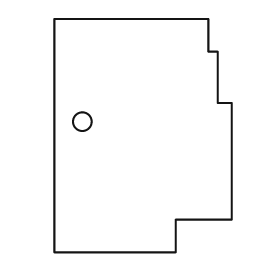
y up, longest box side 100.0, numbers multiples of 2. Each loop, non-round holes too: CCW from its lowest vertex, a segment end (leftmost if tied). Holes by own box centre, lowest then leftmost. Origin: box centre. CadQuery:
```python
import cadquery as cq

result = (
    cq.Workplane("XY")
    .moveTo(-38.0, -50.0)
    .lineTo(14.0, -50.0)
    .lineTo(14.0, -36.0)
    .lineTo(38.0, -36.0)
    .lineTo(38.0, 14.0)
    .lineTo(32.0, 14.0)
    .lineTo(32.0, 36.0)
    .lineTo(28.0, 36.0)
    .lineTo(28.0, 50.0)
    .lineTo(-38.0, 50.0)
    .close()
    .moveTo(-26.0, 6.0)
    .circle(4.0)
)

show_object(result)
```